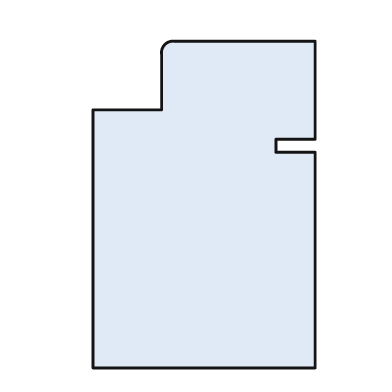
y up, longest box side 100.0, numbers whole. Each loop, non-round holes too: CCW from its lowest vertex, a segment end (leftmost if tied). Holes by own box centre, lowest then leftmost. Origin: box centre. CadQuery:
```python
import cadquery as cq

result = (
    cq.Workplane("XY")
    .moveTo(-34.0, -50.0)
    .lineTo(34.0, -50.0)
    .lineTo(34.0, 16.0)
    .lineTo(22.0, 16.0)
    .lineTo(22.0, 20.0)
    .lineTo(34.0, 20.0)
    .lineTo(34.0, 50.0)
    .lineTo(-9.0, 50.0)
    .threePointArc((-12.0, 49.0), (-13.0, 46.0))
    .lineTo(-13.0, 29.0)
    .lineTo(-34.0, 29.0)
    .close()
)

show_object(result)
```